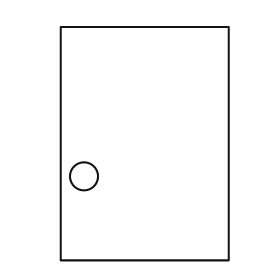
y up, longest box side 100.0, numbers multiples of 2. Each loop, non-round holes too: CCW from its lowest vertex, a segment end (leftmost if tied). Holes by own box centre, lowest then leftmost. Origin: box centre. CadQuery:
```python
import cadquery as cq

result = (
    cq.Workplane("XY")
    .moveTo(-36.0, -50.0)
    .lineTo(36.0, -50.0)
    .lineTo(36.0, 50.0)
    .lineTo(-36.0, 50.0)
    .close()
    .moveTo(-26.0, -14.0)
    .circle(6.0)
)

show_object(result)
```